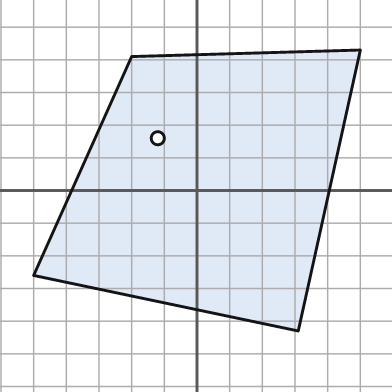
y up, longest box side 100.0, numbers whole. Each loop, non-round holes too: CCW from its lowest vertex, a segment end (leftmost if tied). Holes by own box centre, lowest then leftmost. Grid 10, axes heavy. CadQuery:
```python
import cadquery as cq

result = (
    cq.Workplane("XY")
    .moveTo(31.0, -43.0)
    .lineTo(50.0, 43.0)
    .lineTo(-20.0, 41.0)
    .lineTo(-50.0, -26.0)
    .close()
    .moveTo(-12.0, 16.0)
    .circle(2.0)
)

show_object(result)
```